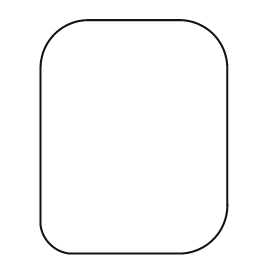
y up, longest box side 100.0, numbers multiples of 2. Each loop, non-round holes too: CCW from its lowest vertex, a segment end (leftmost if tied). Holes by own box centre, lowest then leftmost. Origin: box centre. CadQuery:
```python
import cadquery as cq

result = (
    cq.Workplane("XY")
    .moveTo(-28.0, -50.0)
    .lineTo(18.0, -50.0)
    .threePointArc((34.0, -44.0), (40.0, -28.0))
    .lineTo(40.0, 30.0)
    .threePointArc((34.0, 44.0), (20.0, 50.0))
    .lineTo(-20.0, 50.0)
    .threePointArc((-34.0, 44.0), (-40.0, 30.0))
    .lineTo(-40.0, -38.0)
    .threePointArc((-36.0, -46.0), (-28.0, -50.0))
    .close()
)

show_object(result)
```